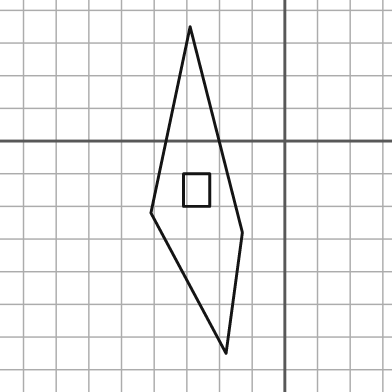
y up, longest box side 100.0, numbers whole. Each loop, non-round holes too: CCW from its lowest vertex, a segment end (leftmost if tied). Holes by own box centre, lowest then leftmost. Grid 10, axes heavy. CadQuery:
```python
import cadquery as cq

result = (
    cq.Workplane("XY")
    .moveTo(-18.0, -65.0)
    .lineTo(-13.0, -28.0)
    .lineTo(-29.0, 35.0)
    .lineTo(-41.0, -22.0)
    .close()
    .moveTo(-31.0, -20.0)
    .lineTo(-23.0, -20.0)
    .lineTo(-23.0, -10.0)
    .lineTo(-31.0, -10.0)
    .close()
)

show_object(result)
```